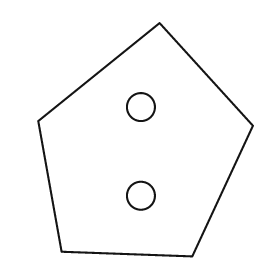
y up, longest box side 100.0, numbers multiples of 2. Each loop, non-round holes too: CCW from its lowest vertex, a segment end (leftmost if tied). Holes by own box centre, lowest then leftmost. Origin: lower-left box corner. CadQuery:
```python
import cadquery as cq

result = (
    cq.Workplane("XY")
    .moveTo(66.0, 0.0)
    .lineTo(92.0, 56.0)
    .lineTo(52.0, 100.0)
    .lineTo(0.0, 58.0)
    .lineTo(10.0, 2.0)
    .close()
    .moveTo(44.0, 26.0)
    .circle(6.0)
    .moveTo(44.0, 64.0)
    .circle(6.0)
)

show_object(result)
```